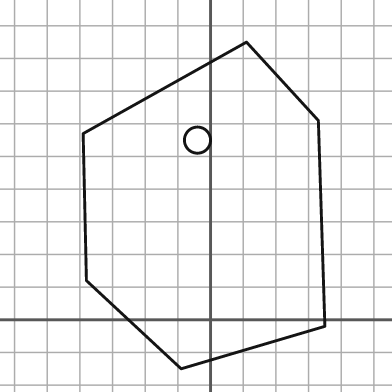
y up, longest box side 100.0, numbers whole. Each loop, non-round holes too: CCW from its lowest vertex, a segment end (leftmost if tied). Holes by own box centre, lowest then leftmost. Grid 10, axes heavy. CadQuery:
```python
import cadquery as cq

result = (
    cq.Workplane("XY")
    .moveTo(-9.0, -15.0)
    .lineTo(35.0, -2.0)
    .lineTo(33.0, 61.0)
    .lineTo(11.0, 85.0)
    .lineTo(-39.0, 57.0)
    .lineTo(-38.0, 12.0)
    .close()
    .moveTo(-4.0, 55.0)
    .circle(4.0)
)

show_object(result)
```